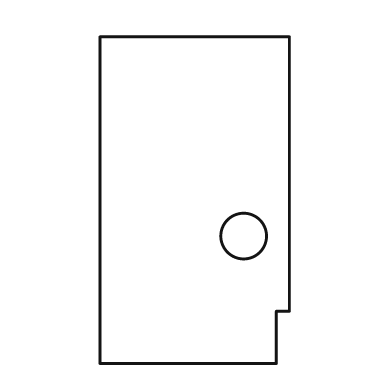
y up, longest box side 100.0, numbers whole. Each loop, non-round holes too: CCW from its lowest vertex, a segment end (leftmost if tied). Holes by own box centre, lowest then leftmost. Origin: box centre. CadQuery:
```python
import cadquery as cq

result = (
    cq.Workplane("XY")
    .moveTo(-29.0, -50.0)
    .lineTo(25.0, -50.0)
    .lineTo(25.0, -34.0)
    .lineTo(29.0, -34.0)
    .lineTo(29.0, 50.0)
    .lineTo(-29.0, 50.0)
    .close()
    .moveTo(15.0, -11.0)
    .circle(7.0)
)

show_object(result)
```